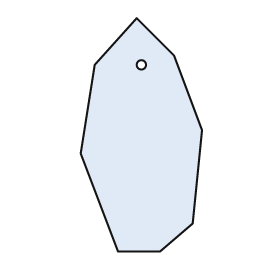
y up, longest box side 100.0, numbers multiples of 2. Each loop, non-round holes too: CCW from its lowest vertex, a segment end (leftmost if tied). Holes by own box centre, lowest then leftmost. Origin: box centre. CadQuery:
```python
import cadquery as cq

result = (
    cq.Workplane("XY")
    .moveTo(-10.0, -50.0)
    .lineTo(8.0, -50.0)
    .lineTo(22.0, -38.0)
    .lineTo(26.0, 2.0)
    .lineTo(14.0, 34.0)
    .lineTo(-2.0, 50.0)
    .lineTo(-20.0, 30.0)
    .lineTo(-26.0, -8.0)
    .close()
    .moveTo(0.0, 30.0)
    .circle(2.0)
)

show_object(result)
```